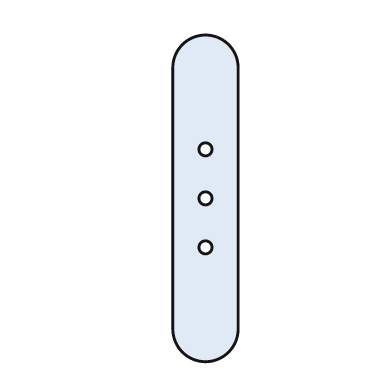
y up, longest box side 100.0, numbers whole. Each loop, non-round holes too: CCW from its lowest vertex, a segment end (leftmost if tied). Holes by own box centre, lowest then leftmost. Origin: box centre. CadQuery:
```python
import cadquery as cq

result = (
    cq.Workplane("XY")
    .moveTo(-10.0, -40.0)
    .threePointArc((0.0, -50.0), (10.0, -40.0))
    .lineTo(10.0, 40.0)
    .threePointArc((0.0, 50.0), (-10.0, 40.0))
    .close()
    .moveTo(0.0, -15.0)
    .circle(2.0)
    .moveTo(0.0, 0.0)
    .circle(2.0)
    .moveTo(0.0, 15.0)
    .circle(2.0)
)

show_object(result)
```